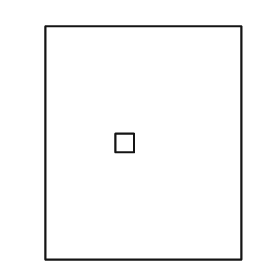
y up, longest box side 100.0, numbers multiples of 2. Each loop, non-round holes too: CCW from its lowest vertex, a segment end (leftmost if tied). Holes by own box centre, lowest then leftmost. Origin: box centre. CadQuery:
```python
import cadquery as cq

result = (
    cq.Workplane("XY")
    .moveTo(-42.0, -50.0)
    .lineTo(42.0, -50.0)
    .lineTo(42.0, 50.0)
    .lineTo(-42.0, 50.0)
    .close()
    .moveTo(-12.0, -4.0)
    .lineTo(-4.0, -4.0)
    .lineTo(-4.0, 4.0)
    .lineTo(-12.0, 4.0)
    .close()
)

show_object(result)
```